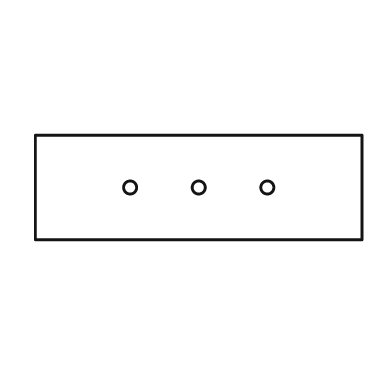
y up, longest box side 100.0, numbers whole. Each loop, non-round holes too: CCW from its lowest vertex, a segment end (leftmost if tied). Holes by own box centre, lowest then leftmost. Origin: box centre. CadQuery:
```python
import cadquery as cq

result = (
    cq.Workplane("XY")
    .moveTo(-50.0, -16.0)
    .lineTo(50.0, -16.0)
    .lineTo(50.0, 16.0)
    .lineTo(-50.0, 16.0)
    .close()
    .moveTo(-21.0, 0.0)
    .circle(2.0)
    .moveTo(0.0, 0.0)
    .circle(2.0)
    .moveTo(21.0, 0.0)
    .circle(2.0)
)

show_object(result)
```